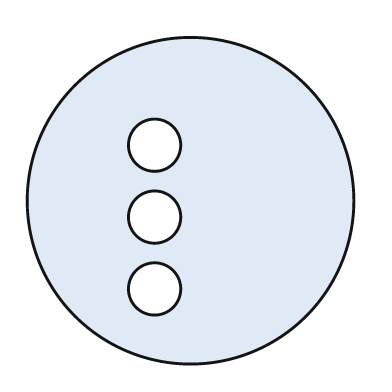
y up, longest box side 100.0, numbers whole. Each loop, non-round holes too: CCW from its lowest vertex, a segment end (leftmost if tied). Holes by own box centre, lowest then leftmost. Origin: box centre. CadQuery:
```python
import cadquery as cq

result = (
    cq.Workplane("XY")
    .moveTo(0.0, 0.0)
    .circle(50.0)
    .moveTo(-11.0, -27.0)
    .circle(8.0)
    .moveTo(-11.0, -5.0)
    .circle(8.0)
    .moveTo(-11.0, 17.0)
    .circle(8.0)
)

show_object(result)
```